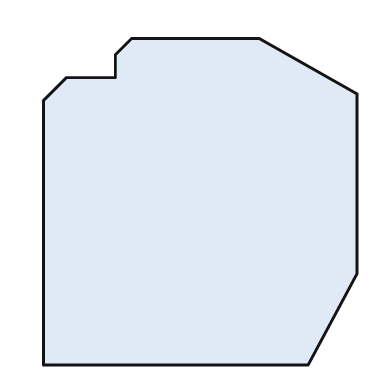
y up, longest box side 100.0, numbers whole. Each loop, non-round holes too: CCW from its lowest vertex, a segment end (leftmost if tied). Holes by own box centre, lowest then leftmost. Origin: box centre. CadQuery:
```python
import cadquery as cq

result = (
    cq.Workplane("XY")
    .moveTo(-48.0, -50.0)
    .lineTo(33.0, -50.0)
    .lineTo(48.0, -22.0)
    .lineTo(48.0, 33.0)
    .lineTo(18.0, 50.0)
    .lineTo(-21.0, 50.0)
    .lineTo(-26.0, 45.0)
    .lineTo(-26.0, 38.0)
    .lineTo(-41.0, 38.0)
    .lineTo(-48.0, 31.0)
    .close()
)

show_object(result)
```